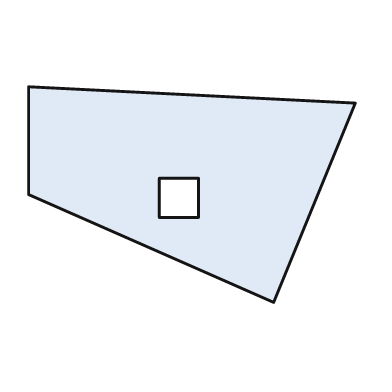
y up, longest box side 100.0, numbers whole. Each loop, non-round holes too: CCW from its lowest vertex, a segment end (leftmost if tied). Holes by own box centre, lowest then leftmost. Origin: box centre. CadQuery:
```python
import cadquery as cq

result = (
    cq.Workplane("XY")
    .moveTo(25.0, -33.0)
    .lineTo(50.0, 28.0)
    .lineTo(-50.0, 33.0)
    .lineTo(-50.0, 0.0)
    .close()
    .moveTo(-10.0, -7.0)
    .lineTo(2.0, -7.0)
    .lineTo(2.0, 5.0)
    .lineTo(-10.0, 5.0)
    .close()
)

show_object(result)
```